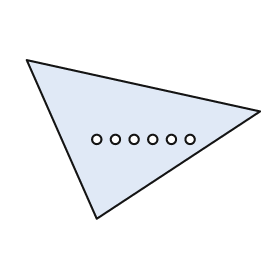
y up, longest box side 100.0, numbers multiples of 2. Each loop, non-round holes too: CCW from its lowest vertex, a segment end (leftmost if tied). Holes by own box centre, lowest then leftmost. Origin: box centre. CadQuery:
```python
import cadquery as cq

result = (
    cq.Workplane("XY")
    .moveTo(-20.0, -34.0)
    .lineTo(50.0, 12.0)
    .lineTo(-50.0, 34.0)
    .close()
    .moveTo(-20.0, 0.0)
    .circle(2.0)
    .moveTo(-12.0, 0.0)
    .circle(2.0)
    .moveTo(-4.0, 0.0)
    .circle(2.0)
    .moveTo(4.0, 0.0)
    .circle(2.0)
    .moveTo(12.0, 0.0)
    .circle(2.0)
    .moveTo(20.0, 0.0)
    .circle(2.0)
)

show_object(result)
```